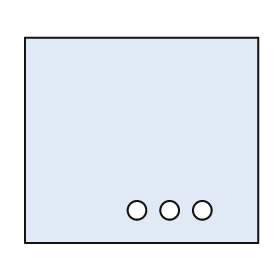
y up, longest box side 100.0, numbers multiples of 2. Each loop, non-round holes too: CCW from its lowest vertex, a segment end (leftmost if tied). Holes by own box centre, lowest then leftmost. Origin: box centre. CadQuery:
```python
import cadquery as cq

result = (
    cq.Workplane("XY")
    .moveTo(-50.0, -44.0)
    .lineTo(50.0, -44.0)
    .lineTo(50.0, 44.0)
    .lineTo(-50.0, 44.0)
    .close()
    .moveTo(-2.0, -30.0)
    .circle(4.0)
    .moveTo(12.0, -30.0)
    .circle(4.0)
    .moveTo(26.0, -30.0)
    .circle(4.0)
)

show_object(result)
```